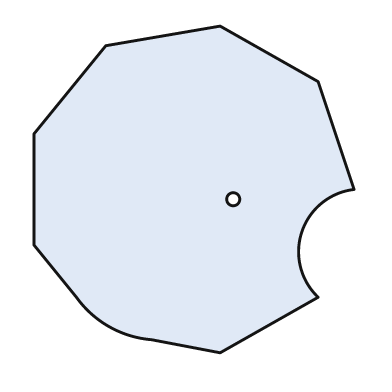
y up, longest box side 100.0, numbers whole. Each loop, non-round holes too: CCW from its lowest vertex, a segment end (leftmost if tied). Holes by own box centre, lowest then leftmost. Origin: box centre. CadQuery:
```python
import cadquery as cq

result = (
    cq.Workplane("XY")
    .moveTo(8.0, -50.0)
    .lineTo(38.0, -33.0)
    .threePointArc((33.0, -13.0), (49.0, 0.0))
    .lineTo(38.0, 33.0)
    .lineTo(8.0, 50.0)
    .lineTo(-27.0, 44.0)
    .lineTo(-49.0, 17.0)
    .lineTo(-49.0, -17.0)
    .lineTo(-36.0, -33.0)
    .threePointArc((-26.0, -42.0), (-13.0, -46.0))
    .close()
    .moveTo(12.0, -3.0)
    .circle(2.0)
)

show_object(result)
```